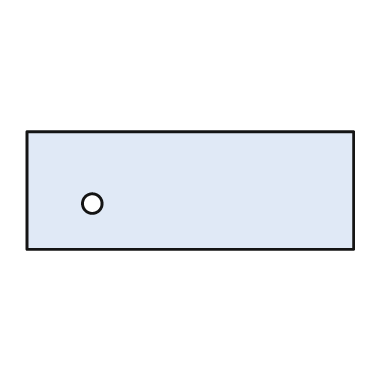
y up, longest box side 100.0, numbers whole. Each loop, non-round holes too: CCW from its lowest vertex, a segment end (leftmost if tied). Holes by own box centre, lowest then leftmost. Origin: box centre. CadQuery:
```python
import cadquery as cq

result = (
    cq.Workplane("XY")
    .moveTo(-50.0, -18.0)
    .lineTo(50.0, -18.0)
    .lineTo(50.0, 18.0)
    .lineTo(-50.0, 18.0)
    .close()
    .moveTo(-30.0, -4.0)
    .circle(3.0)
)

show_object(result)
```